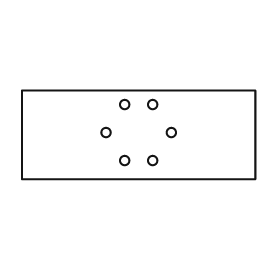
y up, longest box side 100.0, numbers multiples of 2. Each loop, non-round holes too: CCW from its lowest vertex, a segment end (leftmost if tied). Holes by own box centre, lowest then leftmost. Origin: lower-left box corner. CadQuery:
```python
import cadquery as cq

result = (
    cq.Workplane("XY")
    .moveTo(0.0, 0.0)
    .lineTo(100.0, 0.0)
    .lineTo(100.0, 38.0)
    .lineTo(0.0, 38.0)
    .close()
    .moveTo(44.0, 8.0)
    .circle(2.0)
    .moveTo(56.0, 8.0)
    .circle(2.0)
    .moveTo(36.0, 20.0)
    .circle(2.0)
    .moveTo(64.0, 20.0)
    .circle(2.0)
    .moveTo(44.0, 32.0)
    .circle(2.0)
    .moveTo(56.0, 32.0)
    .circle(2.0)
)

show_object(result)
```